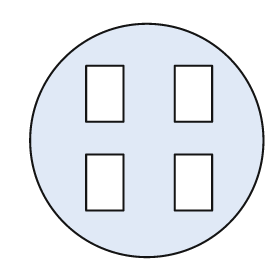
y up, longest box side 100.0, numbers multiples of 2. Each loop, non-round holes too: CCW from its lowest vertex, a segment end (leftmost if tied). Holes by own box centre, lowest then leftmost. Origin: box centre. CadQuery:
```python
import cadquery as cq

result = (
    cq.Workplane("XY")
    .moveTo(0.0, 0.0)
    .circle(50.0)
    .moveTo(-26.0, -30.0)
    .lineTo(-10.0, -30.0)
    .lineTo(-10.0, -6.0)
    .lineTo(-26.0, -6.0)
    .close()
    .moveTo(12.0, -30.0)
    .lineTo(28.0, -30.0)
    .lineTo(28.0, -6.0)
    .lineTo(12.0, -6.0)
    .close()
    .moveTo(-26.0, 8.0)
    .lineTo(-10.0, 8.0)
    .lineTo(-10.0, 32.0)
    .lineTo(-26.0, 32.0)
    .close()
    .moveTo(12.0, 8.0)
    .lineTo(28.0, 8.0)
    .lineTo(28.0, 32.0)
    .lineTo(12.0, 32.0)
    .close()
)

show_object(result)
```